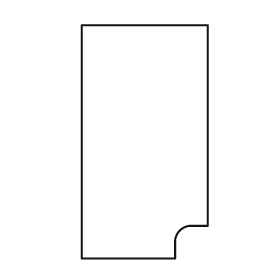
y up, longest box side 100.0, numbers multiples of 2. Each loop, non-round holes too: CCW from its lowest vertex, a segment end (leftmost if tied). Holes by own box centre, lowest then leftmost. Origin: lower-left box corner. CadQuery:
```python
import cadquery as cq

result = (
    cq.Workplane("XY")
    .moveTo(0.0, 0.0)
    .lineTo(40.0, 0.0)
    .lineTo(40.0, 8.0)
    .threePointArc((42.0, 12.0), (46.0, 14.0))
    .lineTo(54.0, 14.0)
    .lineTo(54.0, 100.0)
    .lineTo(0.0, 100.0)
    .close()
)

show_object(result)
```